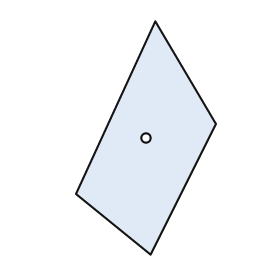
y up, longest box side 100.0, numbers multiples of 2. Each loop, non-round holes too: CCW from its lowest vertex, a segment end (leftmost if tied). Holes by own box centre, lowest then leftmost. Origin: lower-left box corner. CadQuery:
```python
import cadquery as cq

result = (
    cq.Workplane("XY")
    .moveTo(32.0, 0.0)
    .lineTo(60.0, 56.0)
    .lineTo(34.0, 100.0)
    .lineTo(0.0, 26.0)
    .close()
    .moveTo(30.0, 50.0)
    .circle(2.0)
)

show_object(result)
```